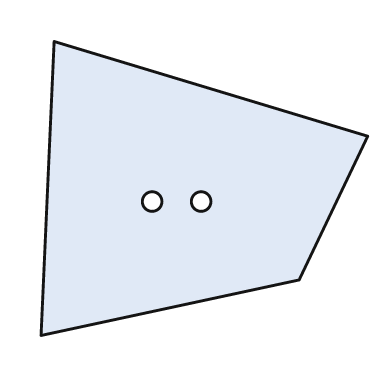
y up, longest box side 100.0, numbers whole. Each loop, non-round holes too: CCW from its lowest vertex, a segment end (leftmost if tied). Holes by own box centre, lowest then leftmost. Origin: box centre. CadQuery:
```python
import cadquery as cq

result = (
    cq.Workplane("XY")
    .moveTo(-50.0, -45.0)
    .lineTo(29.0, -28.0)
    .lineTo(50.0, 16.0)
    .lineTo(-46.0, 45.0)
    .close()
    .moveTo(-16.0, -4.0)
    .circle(3.0)
    .moveTo(-1.0, -4.0)
    .circle(3.0)
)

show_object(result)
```